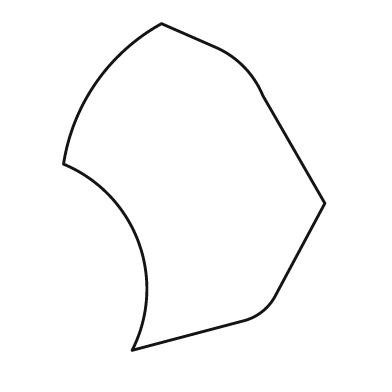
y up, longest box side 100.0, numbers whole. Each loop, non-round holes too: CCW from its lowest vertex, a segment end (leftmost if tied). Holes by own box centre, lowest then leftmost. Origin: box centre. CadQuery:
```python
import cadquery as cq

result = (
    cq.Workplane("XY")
    .moveTo(-19.0, -50.0)
    .lineTo(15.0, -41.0)
    .threePointArc((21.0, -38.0), (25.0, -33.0))
    .lineTo(40.0, -5.0)
    .lineTo(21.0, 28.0)
    .threePointArc((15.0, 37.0), (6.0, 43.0))
    .lineTo(-10.0, 50.0)
    .threePointArc((-30.0, 32.0), (-40.0, 7.0))
    .threePointArc((-17.0, -17.0), (-19.0, -50.0))
    .close()
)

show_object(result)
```